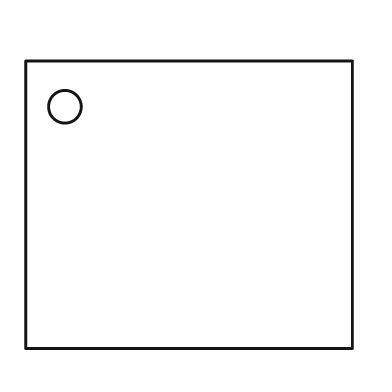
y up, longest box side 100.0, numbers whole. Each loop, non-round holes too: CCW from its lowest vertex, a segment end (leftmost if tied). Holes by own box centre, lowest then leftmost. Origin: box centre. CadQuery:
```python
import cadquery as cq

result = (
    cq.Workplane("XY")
    .moveTo(-50.0, -44.0)
    .lineTo(50.0, -44.0)
    .lineTo(50.0, 44.0)
    .lineTo(-50.0, 44.0)
    .close()
    .moveTo(-38.0, 30.0)
    .circle(5.0)
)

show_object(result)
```